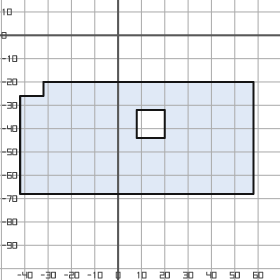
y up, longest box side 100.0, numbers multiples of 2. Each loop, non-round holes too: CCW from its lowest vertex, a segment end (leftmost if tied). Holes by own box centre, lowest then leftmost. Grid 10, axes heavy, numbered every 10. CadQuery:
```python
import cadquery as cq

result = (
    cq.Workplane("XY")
    .moveTo(-42.0, -68.0)
    .lineTo(58.0, -68.0)
    .lineTo(58.0, -20.0)
    .lineTo(-32.0, -20.0)
    .lineTo(-32.0, -26.0)
    .lineTo(-42.0, -26.0)
    .close()
    .moveTo(8.0, -44.0)
    .lineTo(20.0, -44.0)
    .lineTo(20.0, -32.0)
    .lineTo(8.0, -32.0)
    .close()
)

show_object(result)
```